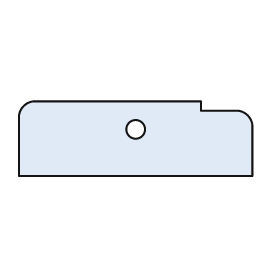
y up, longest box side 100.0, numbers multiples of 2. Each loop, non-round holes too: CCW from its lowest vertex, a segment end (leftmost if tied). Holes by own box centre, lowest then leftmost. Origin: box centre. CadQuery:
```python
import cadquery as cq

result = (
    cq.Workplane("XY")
    .moveTo(-50.0, -16.0)
    .lineTo(50.0, -16.0)
    .lineTo(50.0, 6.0)
    .threePointArc((48.0, 10.0), (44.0, 12.0))
    .lineTo(28.0, 12.0)
    .lineTo(28.0, 16.0)
    .lineTo(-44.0, 16.0)
    .threePointArc((-48.0, 14.0), (-50.0, 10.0))
    .close()
    .moveTo(0.0, 4.0)
    .circle(4.0)
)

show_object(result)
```